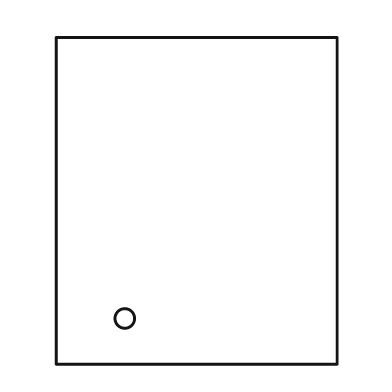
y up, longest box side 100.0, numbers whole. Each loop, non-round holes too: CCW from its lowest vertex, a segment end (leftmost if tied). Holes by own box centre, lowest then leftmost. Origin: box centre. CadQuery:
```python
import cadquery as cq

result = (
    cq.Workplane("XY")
    .moveTo(-43.0, -50.0)
    .lineTo(43.0, -50.0)
    .lineTo(43.0, 50.0)
    .lineTo(-43.0, 50.0)
    .close()
    .moveTo(-22.0, -36.0)
    .circle(3.0)
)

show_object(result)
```